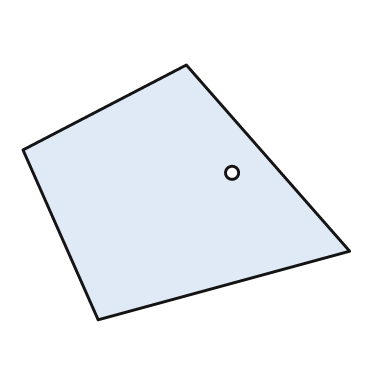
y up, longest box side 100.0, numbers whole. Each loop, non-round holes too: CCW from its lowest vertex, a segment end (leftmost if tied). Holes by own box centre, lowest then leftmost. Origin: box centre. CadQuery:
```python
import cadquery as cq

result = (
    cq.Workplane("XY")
    .moveTo(-27.0, -39.0)
    .lineTo(50.0, -18.0)
    .lineTo(0.0, 39.0)
    .lineTo(-50.0, 13.0)
    .close()
    .moveTo(14.0, 6.0)
    .circle(2.0)
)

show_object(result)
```